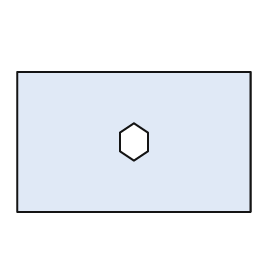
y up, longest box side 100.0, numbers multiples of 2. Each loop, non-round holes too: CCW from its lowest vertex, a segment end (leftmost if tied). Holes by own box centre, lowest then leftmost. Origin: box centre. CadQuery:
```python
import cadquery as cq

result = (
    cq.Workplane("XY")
    .moveTo(-50.0, -30.0)
    .lineTo(50.0, -30.0)
    .lineTo(50.0, 30.0)
    .lineTo(-50.0, 30.0)
    .close()
    .moveTo(0.0, -8.0)
    .lineTo(6.0, -4.0)
    .lineTo(6.0, 4.0)
    .lineTo(0.0, 8.0)
    .lineTo(-6.0, 4.0)
    .lineTo(-6.0, -4.0)
    .close()
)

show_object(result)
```